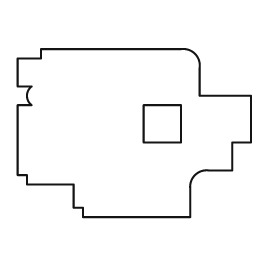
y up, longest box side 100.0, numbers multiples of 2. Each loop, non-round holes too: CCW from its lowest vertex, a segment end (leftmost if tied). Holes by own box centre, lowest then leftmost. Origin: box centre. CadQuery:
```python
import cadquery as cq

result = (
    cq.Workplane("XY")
    .moveTo(-22.0, -36.0)
    .lineTo(24.0, -36.0)
    .lineTo(24.0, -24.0)
    .threePointArc((26.0, -18.0), (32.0, -16.0))
    .lineTo(42.0, -16.0)
    .lineTo(42.0, -4.0)
    .lineTo(50.0, -4.0)
    .lineTo(50.0, 16.0)
    .lineTo(28.0, 16.0)
    .lineTo(28.0, 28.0)
    .threePointArc((26.0, 34.0), (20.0, 36.0))
    .lineTo(-40.0, 36.0)
    .lineTo(-40.0, 32.0)
    .lineTo(-50.0, 32.0)
    .lineTo(-50.0, 20.0)
    .lineTo(-44.0, 20.0)
    .threePointArc((-46.0, 16.0), (-44.0, 12.0))
    .lineTo(-50.0, 12.0)
    .lineTo(-50.0, -18.0)
    .lineTo(-46.0, -18.0)
    .lineTo(-46.0, -22.0)
    .lineTo(-26.0, -22.0)
    .lineTo(-26.0, -32.0)
    .lineTo(-22.0, -32.0)
    .close()
    .moveTo(4.0, -4.0)
    .lineTo(20.0, -4.0)
    .lineTo(20.0, 12.0)
    .lineTo(4.0, 12.0)
    .close()
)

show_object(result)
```